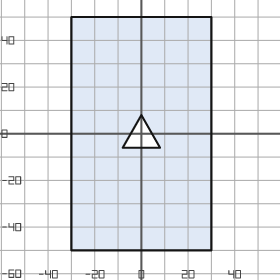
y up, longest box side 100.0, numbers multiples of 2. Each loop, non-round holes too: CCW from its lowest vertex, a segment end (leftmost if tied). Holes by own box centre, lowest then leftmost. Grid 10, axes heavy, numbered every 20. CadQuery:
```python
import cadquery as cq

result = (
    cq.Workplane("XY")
    .moveTo(-30.0, -50.0)
    .lineTo(30.0, -50.0)
    .lineTo(30.0, 50.0)
    .lineTo(-30.0, 50.0)
    .close()
    .moveTo(-8.0, -6.0)
    .lineTo(8.0, -6.0)
    .lineTo(0.0, 8.0)
    .close()
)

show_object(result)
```